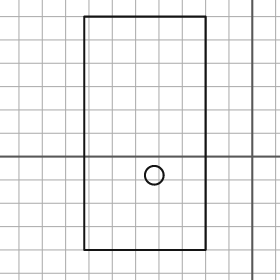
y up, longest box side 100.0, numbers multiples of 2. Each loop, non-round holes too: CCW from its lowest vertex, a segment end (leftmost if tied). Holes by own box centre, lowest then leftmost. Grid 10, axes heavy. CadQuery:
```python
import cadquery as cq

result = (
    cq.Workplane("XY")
    .moveTo(-72.0, -40.0)
    .lineTo(-20.0, -40.0)
    .lineTo(-20.0, 60.0)
    .lineTo(-72.0, 60.0)
    .close()
    .moveTo(-42.0, -8.0)
    .circle(4.0)
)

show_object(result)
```